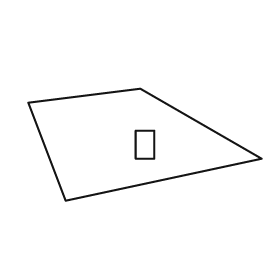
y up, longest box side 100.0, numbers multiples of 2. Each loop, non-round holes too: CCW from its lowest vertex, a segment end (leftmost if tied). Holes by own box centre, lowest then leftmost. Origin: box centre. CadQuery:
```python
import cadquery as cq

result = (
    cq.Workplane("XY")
    .moveTo(-34.0, -24.0)
    .lineTo(50.0, -6.0)
    .lineTo(-2.0, 24.0)
    .lineTo(-50.0, 18.0)
    .close()
    .moveTo(-4.0, -6.0)
    .lineTo(4.0, -6.0)
    .lineTo(4.0, 6.0)
    .lineTo(-4.0, 6.0)
    .close()
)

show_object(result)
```